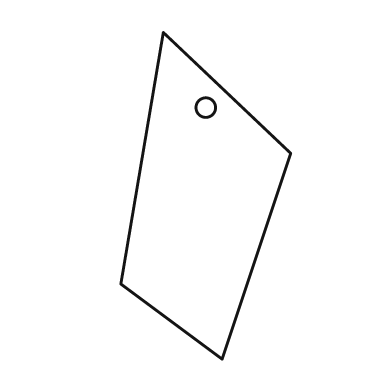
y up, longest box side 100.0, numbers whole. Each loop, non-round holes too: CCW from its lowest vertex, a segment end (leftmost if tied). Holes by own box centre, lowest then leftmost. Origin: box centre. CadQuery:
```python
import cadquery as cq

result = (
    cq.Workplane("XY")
    .moveTo(5.0, -50.0)
    .lineTo(26.0, 13.0)
    .lineTo(-13.0, 50.0)
    .lineTo(-26.0, -27.0)
    .close()
    .moveTo(0.0, 27.0)
    .circle(3.0)
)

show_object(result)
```